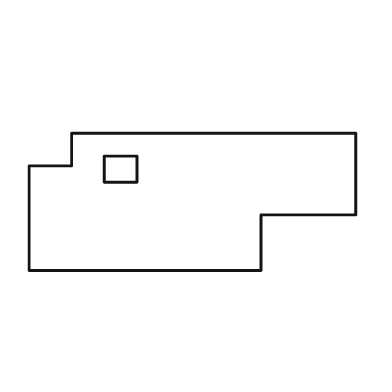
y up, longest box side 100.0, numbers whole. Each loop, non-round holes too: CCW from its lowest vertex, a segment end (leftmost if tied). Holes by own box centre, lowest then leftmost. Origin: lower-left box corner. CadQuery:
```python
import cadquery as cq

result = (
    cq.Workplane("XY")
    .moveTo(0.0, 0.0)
    .lineTo(71.0, 0.0)
    .lineTo(71.0, 17.0)
    .lineTo(100.0, 17.0)
    .lineTo(100.0, 42.0)
    .lineTo(13.0, 42.0)
    .lineTo(13.0, 32.0)
    .lineTo(0.0, 32.0)
    .close()
    .moveTo(23.0, 27.0)
    .lineTo(33.0, 27.0)
    .lineTo(33.0, 35.0)
    .lineTo(23.0, 35.0)
    .close()
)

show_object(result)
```